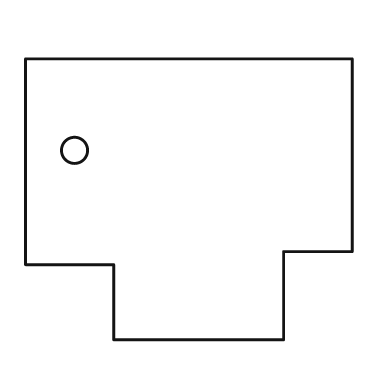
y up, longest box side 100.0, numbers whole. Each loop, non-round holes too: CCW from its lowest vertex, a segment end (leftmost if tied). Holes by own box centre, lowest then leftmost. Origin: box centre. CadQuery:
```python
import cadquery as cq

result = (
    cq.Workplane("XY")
    .moveTo(-23.0, -43.0)
    .lineTo(29.0, -43.0)
    .lineTo(29.0, -16.0)
    .lineTo(50.0, -16.0)
    .lineTo(50.0, 43.0)
    .lineTo(-50.0, 43.0)
    .lineTo(-50.0, -20.0)
    .lineTo(-23.0, -20.0)
    .close()
    .moveTo(-35.0, 15.0)
    .circle(4.0)
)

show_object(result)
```